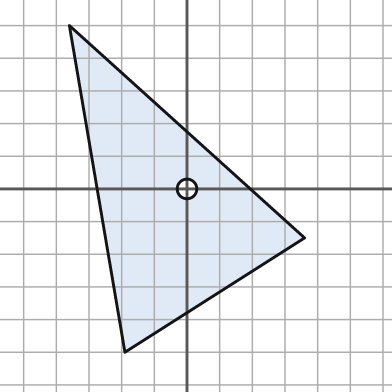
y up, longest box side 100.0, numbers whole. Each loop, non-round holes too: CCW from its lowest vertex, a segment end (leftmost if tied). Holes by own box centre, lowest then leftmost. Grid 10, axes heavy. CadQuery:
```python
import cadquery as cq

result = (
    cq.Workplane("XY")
    .moveTo(-19.0, -50.0)
    .lineTo(36.0, -15.0)
    .lineTo(-36.0, 50.0)
    .close()
    .moveTo(0.0, 0.0)
    .circle(3.0)
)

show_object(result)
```